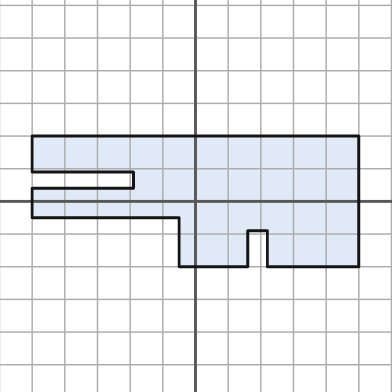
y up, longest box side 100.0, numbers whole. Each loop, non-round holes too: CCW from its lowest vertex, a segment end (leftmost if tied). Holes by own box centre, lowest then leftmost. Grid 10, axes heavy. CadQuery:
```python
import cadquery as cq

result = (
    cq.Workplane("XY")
    .moveTo(-5.0, -20.0)
    .lineTo(16.0, -20.0)
    .lineTo(16.0, -9.0)
    .lineTo(22.0, -9.0)
    .lineTo(22.0, -20.0)
    .lineTo(50.0, -20.0)
    .lineTo(50.0, 20.0)
    .lineTo(-50.0, 20.0)
    .lineTo(-50.0, 9.0)
    .lineTo(-19.0, 9.0)
    .lineTo(-19.0, 4.0)
    .lineTo(-50.0, 4.0)
    .lineTo(-50.0, -5.0)
    .lineTo(-5.0, -5.0)
    .close()
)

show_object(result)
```